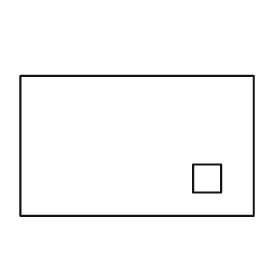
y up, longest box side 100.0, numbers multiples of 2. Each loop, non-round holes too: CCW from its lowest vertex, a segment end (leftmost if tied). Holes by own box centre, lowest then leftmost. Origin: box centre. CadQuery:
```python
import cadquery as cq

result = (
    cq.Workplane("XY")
    .moveTo(-50.0, -30.0)
    .lineTo(50.0, -30.0)
    .lineTo(50.0, 30.0)
    .lineTo(-50.0, 30.0)
    .close()
    .moveTo(24.0, -20.0)
    .lineTo(36.0, -20.0)
    .lineTo(36.0, -8.0)
    .lineTo(24.0, -8.0)
    .close()
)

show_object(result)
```